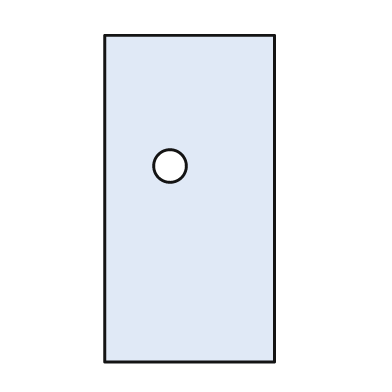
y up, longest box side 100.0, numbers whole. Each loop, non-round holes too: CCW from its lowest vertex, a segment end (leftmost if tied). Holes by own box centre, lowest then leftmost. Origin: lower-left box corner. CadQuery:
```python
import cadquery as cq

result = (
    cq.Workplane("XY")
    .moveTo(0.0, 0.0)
    .lineTo(52.0, 0.0)
    .lineTo(52.0, 100.0)
    .lineTo(0.0, 100.0)
    .close()
    .moveTo(20.0, 60.0)
    .circle(5.0)
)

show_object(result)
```